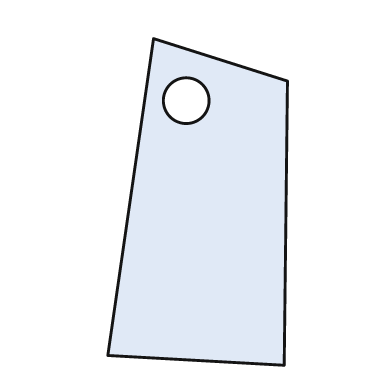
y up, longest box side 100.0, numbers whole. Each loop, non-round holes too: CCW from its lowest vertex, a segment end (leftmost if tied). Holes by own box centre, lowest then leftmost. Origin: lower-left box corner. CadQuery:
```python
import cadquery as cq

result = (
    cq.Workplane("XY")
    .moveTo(54.0, 0.0)
    .lineTo(55.0, 87.0)
    .lineTo(14.0, 100.0)
    .lineTo(0.0, 3.0)
    .close()
    .moveTo(24.0, 81.0)
    .circle(7.0)
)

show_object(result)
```